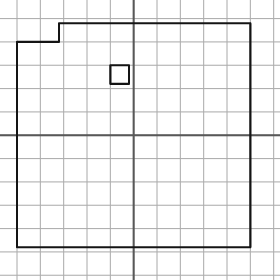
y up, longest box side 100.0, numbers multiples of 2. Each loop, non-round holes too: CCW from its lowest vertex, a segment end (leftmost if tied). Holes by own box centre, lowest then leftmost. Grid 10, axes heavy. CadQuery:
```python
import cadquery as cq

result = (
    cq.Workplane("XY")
    .moveTo(-50.0, -48.0)
    .lineTo(50.0, -48.0)
    .lineTo(50.0, 48.0)
    .lineTo(-32.0, 48.0)
    .lineTo(-32.0, 40.0)
    .lineTo(-50.0, 40.0)
    .close()
    .moveTo(-10.0, 22.0)
    .lineTo(-2.0, 22.0)
    .lineTo(-2.0, 30.0)
    .lineTo(-10.0, 30.0)
    .close()
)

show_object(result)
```